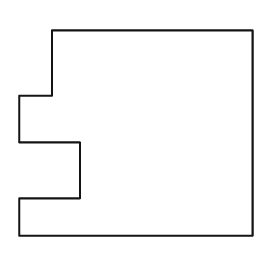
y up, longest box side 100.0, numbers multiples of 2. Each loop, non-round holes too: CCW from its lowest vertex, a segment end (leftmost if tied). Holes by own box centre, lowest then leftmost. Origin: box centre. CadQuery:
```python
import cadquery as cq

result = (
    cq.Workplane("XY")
    .moveTo(-50.0, -44.0)
    .lineTo(50.0, -44.0)
    .lineTo(50.0, 44.0)
    .lineTo(-36.0, 44.0)
    .lineTo(-36.0, 16.0)
    .lineTo(-50.0, 16.0)
    .lineTo(-50.0, -4.0)
    .lineTo(-24.0, -4.0)
    .lineTo(-24.0, -28.0)
    .lineTo(-50.0, -28.0)
    .close()
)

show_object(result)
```